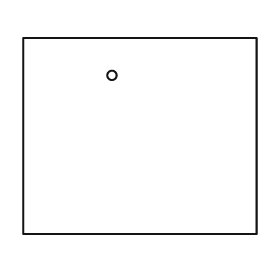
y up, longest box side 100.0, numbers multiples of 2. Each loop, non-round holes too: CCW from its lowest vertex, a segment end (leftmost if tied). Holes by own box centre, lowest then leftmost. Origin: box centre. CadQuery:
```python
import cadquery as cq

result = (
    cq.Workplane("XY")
    .moveTo(-50.0, -42.0)
    .lineTo(50.0, -42.0)
    .lineTo(50.0, 42.0)
    .lineTo(-50.0, 42.0)
    .close()
    .moveTo(-12.0, 26.0)
    .circle(2.0)
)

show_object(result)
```